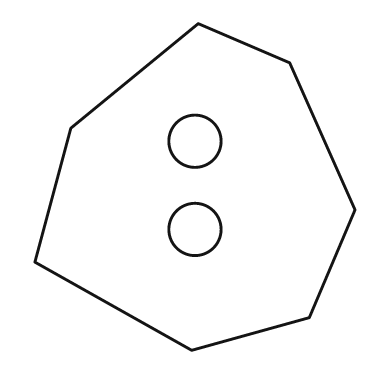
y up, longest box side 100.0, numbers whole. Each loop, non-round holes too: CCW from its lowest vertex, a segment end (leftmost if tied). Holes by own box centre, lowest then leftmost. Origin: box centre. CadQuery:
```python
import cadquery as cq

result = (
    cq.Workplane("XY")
    .moveTo(-1.0, -50.0)
    .lineTo(35.0, -40.0)
    .lineTo(49.0, -7.0)
    .lineTo(29.0, 38.0)
    .lineTo(1.0, 50.0)
    .lineTo(-38.0, 18.0)
    .lineTo(-49.0, -23.0)
    .close()
    .moveTo(0.0, -13.0)
    .circle(8.0)
    .moveTo(0.0, 14.0)
    .circle(8.0)
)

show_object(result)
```